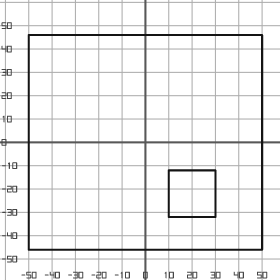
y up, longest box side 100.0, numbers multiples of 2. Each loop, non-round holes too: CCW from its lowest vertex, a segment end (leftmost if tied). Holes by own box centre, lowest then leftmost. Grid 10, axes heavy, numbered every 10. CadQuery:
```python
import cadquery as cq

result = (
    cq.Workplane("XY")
    .moveTo(-50.0, -46.0)
    .lineTo(50.0, -46.0)
    .lineTo(50.0, 46.0)
    .lineTo(-50.0, 46.0)
    .close()
    .moveTo(10.0, -32.0)
    .lineTo(30.0, -32.0)
    .lineTo(30.0, -12.0)
    .lineTo(10.0, -12.0)
    .close()
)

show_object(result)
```